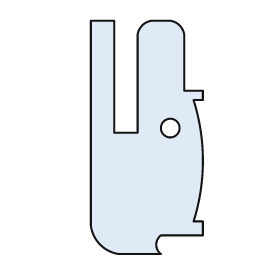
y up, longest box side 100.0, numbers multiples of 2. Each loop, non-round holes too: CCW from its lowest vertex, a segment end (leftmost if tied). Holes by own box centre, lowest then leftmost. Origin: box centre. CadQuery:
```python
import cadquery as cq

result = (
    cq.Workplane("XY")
    .moveTo(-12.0, -50.0)
    .lineTo(6.0, -50.0)
    .threePointArc((4.0, -46.0), (6.0, -42.0))
    .lineTo(24.0, -42.0)
    .lineTo(24.0, -36.0)
    .lineTo(20.0, -36.0)
    .threePointArc((24.0, -10.0), (20.0, 16.0))
    .lineTo(24.0, 16.0)
    .lineTo(24.0, 20.0)
    .lineTo(16.0, 20.0)
    .lineTo(16.0, 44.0)
    .threePointArc((14.0, 48.0), (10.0, 50.0))
    .lineTo(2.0, 50.0)
    .threePointArc((-2.0, 48.0), (-4.0, 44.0))
    .lineTo(-4.0, 2.0)
    .lineTo(-14.0, 2.0)
    .lineTo(-14.0, 50.0)
    .lineTo(-24.0, 50.0)
    .lineTo(-24.0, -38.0)
    .threePointArc((-20.0, -46.0), (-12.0, -50.0))
    .close()
    .moveTo(10.0, 4.0)
    .circle(4.0)
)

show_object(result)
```